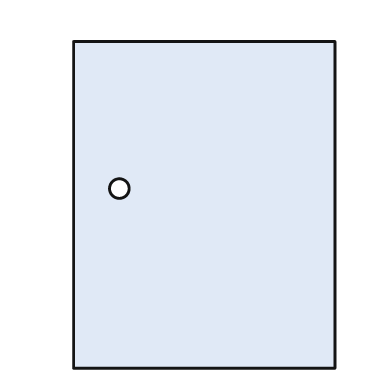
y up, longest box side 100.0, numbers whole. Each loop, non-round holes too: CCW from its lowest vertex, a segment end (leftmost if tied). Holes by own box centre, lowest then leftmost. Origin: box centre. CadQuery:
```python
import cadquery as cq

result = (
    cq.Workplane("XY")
    .moveTo(-40.0, -50.0)
    .lineTo(40.0, -50.0)
    .lineTo(40.0, 50.0)
    .lineTo(-40.0, 50.0)
    .close()
    .moveTo(-26.0, 5.0)
    .circle(3.0)
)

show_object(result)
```